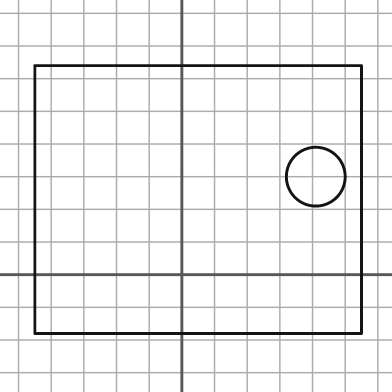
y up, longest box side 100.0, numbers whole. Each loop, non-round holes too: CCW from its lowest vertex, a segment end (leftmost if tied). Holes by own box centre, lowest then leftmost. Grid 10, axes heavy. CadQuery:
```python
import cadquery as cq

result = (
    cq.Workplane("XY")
    .moveTo(-45.0, -18.0)
    .lineTo(55.0, -18.0)
    .lineTo(55.0, 64.0)
    .lineTo(-45.0, 64.0)
    .close()
    .moveTo(41.0, 30.0)
    .circle(9.0)
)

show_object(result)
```